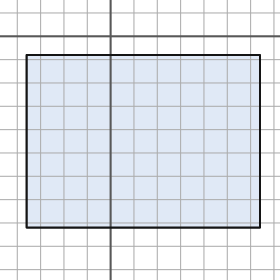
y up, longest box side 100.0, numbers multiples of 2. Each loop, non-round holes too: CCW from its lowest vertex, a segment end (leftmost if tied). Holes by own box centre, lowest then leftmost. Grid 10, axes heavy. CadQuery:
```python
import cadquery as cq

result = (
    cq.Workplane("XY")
    .moveTo(-36.0, -82.0)
    .lineTo(64.0, -82.0)
    .lineTo(64.0, -8.0)
    .lineTo(-36.0, -8.0)
    .close()
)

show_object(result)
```